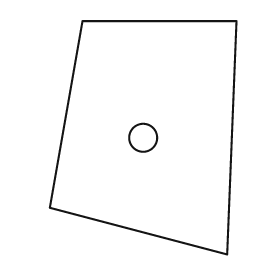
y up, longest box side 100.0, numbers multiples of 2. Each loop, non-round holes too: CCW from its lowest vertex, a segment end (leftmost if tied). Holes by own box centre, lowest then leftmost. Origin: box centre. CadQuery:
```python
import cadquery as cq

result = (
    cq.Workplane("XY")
    .moveTo(36.0, -50.0)
    .lineTo(40.0, 50.0)
    .lineTo(-26.0, 50.0)
    .lineTo(-40.0, -30.0)
    .close()
    .moveTo(0.0, 0.0)
    .circle(6.0)
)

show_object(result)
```